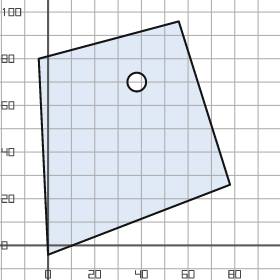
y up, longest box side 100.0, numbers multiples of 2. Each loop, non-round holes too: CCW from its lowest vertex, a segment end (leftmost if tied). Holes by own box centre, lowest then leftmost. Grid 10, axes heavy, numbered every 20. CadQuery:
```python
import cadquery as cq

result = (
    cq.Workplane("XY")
    .moveTo(0.0, -4.0)
    .lineTo(78.0, 26.0)
    .lineTo(56.0, 96.0)
    .lineTo(-4.0, 80.0)
    .close()
    .moveTo(38.0, 70.0)
    .circle(4.0)
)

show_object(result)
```